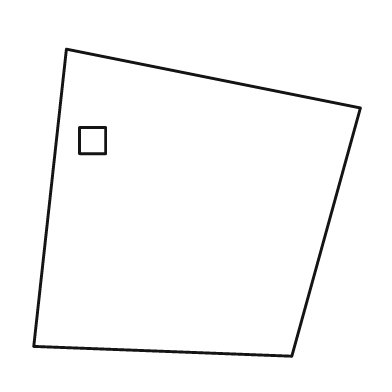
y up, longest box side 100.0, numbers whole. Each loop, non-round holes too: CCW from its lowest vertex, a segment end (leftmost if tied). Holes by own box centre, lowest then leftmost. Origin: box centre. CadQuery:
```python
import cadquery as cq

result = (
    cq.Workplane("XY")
    .moveTo(29.0, -47.0)
    .lineTo(50.0, 29.0)
    .lineTo(-40.0, 47.0)
    .lineTo(-50.0, -44.0)
    .close()
    .moveTo(-36.0, 15.0)
    .lineTo(-28.0, 15.0)
    .lineTo(-28.0, 23.0)
    .lineTo(-36.0, 23.0)
    .close()
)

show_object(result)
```